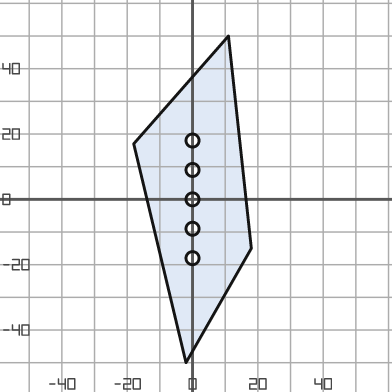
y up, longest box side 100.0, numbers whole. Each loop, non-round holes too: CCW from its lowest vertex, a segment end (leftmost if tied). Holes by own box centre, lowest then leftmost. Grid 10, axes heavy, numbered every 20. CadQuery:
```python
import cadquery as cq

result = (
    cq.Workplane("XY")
    .moveTo(-2.0, -50.0)
    .lineTo(18.0, -15.0)
    .lineTo(11.0, 50.0)
    .lineTo(-18.0, 17.0)
    .close()
    .moveTo(0.0, -18.0)
    .circle(2.0)
    .moveTo(0.0, -9.0)
    .circle(2.0)
    .moveTo(0.0, 0.0)
    .circle(2.0)
    .moveTo(0.0, 9.0)
    .circle(2.0)
    .moveTo(0.0, 18.0)
    .circle(2.0)
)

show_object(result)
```